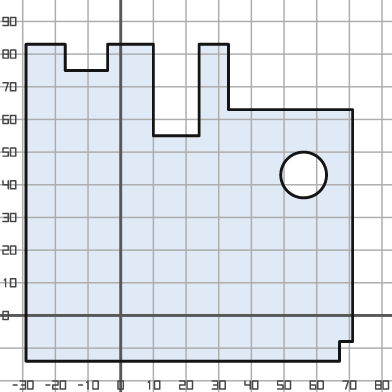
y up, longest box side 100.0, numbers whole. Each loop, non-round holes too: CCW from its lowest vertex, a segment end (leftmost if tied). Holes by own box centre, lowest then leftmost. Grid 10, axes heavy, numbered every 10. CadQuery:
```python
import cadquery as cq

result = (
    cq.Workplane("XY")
    .moveTo(-29.0, -14.0)
    .lineTo(67.0, -14.0)
    .lineTo(67.0, -8.0)
    .lineTo(71.0, -8.0)
    .lineTo(71.0, 63.0)
    .lineTo(33.0, 63.0)
    .lineTo(33.0, 83.0)
    .lineTo(24.0, 83.0)
    .lineTo(24.0, 55.0)
    .lineTo(10.0, 55.0)
    .lineTo(10.0, 83.0)
    .lineTo(-4.0, 83.0)
    .lineTo(-4.0, 75.0)
    .lineTo(-17.0, 75.0)
    .lineTo(-17.0, 83.0)
    .lineTo(-29.0, 83.0)
    .close()
    .moveTo(56.0, 43.0)
    .circle(7.0)
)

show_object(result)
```